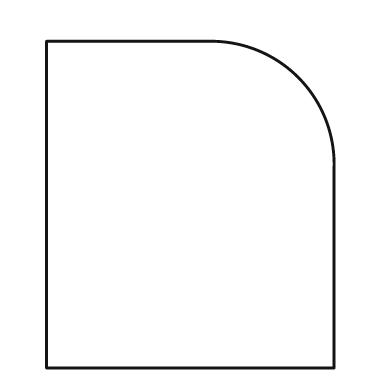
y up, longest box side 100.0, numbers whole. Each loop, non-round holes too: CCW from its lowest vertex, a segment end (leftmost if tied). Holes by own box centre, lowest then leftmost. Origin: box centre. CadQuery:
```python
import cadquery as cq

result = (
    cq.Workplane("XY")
    .moveTo(-44.0, -50.0)
    .lineTo(44.0, -50.0)
    .lineTo(44.0, 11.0)
    .threePointArc((33.0, 39.0), (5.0, 50.0))
    .lineTo(-44.0, 50.0)
    .close()
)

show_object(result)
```